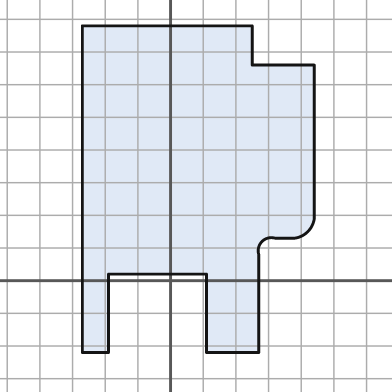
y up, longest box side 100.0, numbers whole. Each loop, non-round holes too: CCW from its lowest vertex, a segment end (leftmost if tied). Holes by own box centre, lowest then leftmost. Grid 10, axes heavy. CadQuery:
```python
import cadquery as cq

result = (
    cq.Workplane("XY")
    .moveTo(-27.0, -22.0)
    .lineTo(-19.0, -22.0)
    .lineTo(-19.0, 2.0)
    .lineTo(11.0, 2.0)
    .lineTo(11.0, -22.0)
    .lineTo(27.0, -22.0)
    .lineTo(27.0, 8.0)
    .threePointArc((28.0, 12.0), (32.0, 13.0))
    .lineTo(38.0, 13.0)
    .threePointArc((42.0, 15.0), (44.0, 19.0))
    .lineTo(44.0, 66.0)
    .lineTo(25.0, 66.0)
    .lineTo(25.0, 78.0)
    .lineTo(-27.0, 78.0)
    .close()
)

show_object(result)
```